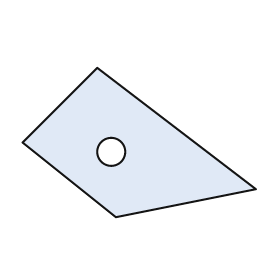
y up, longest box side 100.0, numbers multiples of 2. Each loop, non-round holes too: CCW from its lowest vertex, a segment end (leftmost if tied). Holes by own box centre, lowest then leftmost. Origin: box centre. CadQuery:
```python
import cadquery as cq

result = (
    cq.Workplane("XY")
    .moveTo(-10.0, -32.0)
    .lineTo(50.0, -20.0)
    .lineTo(-18.0, 32.0)
    .lineTo(-50.0, 0.0)
    .close()
    .moveTo(-12.0, -4.0)
    .circle(6.0)
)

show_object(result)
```